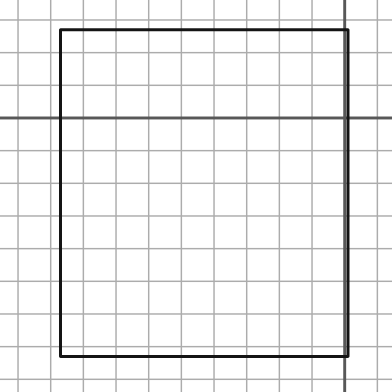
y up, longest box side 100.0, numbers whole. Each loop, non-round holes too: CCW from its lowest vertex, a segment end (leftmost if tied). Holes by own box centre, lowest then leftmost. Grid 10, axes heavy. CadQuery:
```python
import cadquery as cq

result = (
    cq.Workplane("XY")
    .moveTo(-87.0, -73.0)
    .lineTo(1.0, -73.0)
    .lineTo(1.0, 27.0)
    .lineTo(-87.0, 27.0)
    .close()
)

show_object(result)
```